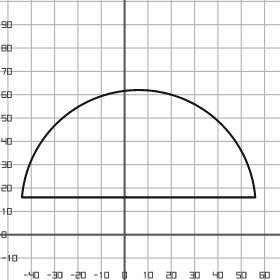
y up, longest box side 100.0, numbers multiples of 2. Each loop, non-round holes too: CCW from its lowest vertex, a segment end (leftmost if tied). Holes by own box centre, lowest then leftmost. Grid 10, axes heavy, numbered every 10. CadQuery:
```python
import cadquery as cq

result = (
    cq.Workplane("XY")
    .moveTo(-44.0, 16.0)
    .lineTo(56.0, 16.0)
    .threePointArc((6.0, 62.0), (-44.0, 16.0))
    .close()
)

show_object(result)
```